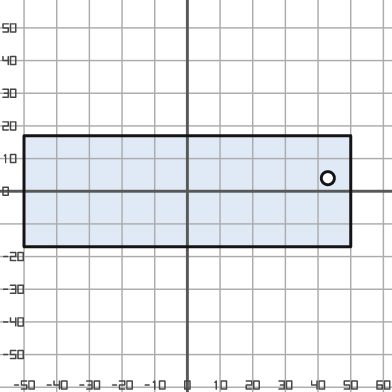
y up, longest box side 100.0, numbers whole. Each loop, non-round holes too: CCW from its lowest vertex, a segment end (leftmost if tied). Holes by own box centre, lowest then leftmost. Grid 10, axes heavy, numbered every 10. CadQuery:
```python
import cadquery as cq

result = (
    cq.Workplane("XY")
    .moveTo(-50.0, -17.0)
    .lineTo(50.0, -17.0)
    .lineTo(50.0, 17.0)
    .lineTo(-50.0, 17.0)
    .close()
    .moveTo(43.0, 4.0)
    .circle(2.0)
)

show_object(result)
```